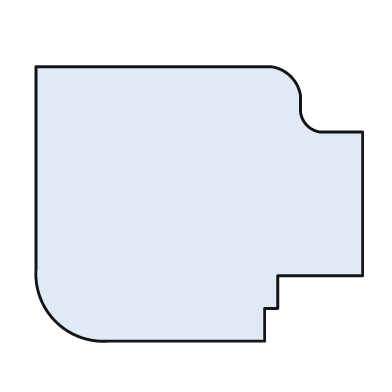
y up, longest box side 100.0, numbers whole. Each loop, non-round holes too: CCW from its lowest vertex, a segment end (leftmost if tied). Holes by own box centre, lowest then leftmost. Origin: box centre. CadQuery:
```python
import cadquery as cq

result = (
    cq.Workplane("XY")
    .moveTo(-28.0, -42.0)
    .lineTo(20.0, -42.0)
    .lineTo(20.0, -32.0)
    .lineTo(24.0, -32.0)
    .lineTo(24.0, -22.0)
    .lineTo(50.0, -22.0)
    .lineTo(50.0, 22.0)
    .lineTo(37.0, 22.0)
    .threePointArc((33.0, 24.0), (31.0, 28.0))
    .lineTo(31.0, 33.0)
    .threePointArc((28.0, 39.0), (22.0, 42.0))
    .lineTo(-50.0, 42.0)
    .lineTo(-50.0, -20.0)
    .threePointArc((-44.0, -36.0), (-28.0, -42.0))
    .close()
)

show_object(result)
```